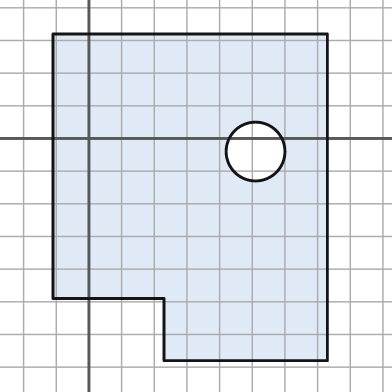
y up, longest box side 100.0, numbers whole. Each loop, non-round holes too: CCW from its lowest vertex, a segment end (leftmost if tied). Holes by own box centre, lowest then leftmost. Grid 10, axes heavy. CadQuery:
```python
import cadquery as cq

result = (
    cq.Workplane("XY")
    .moveTo(23.0, -68.0)
    .lineTo(73.0, -68.0)
    .lineTo(73.0, 32.0)
    .lineTo(-11.0, 32.0)
    .lineTo(-11.0, -49.0)
    .lineTo(23.0, -49.0)
    .close()
    .moveTo(51.0, -4.0)
    .circle(9.0)
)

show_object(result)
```